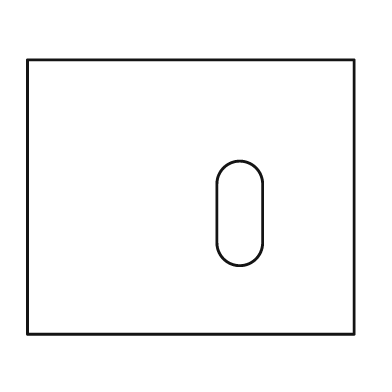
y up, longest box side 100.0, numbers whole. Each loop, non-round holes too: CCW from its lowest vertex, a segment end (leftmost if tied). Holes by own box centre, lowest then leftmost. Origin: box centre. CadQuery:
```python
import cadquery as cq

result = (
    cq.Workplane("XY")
    .moveTo(-50.0, -42.0)
    .lineTo(50.0, -42.0)
    .lineTo(50.0, 42.0)
    .lineTo(-50.0, 42.0)
    .close()
    .moveTo(8.0, -14.0)
    .threePointArc((15.0, -21.0), (22.0, -14.0))
    .lineTo(22.0, 4.0)
    .threePointArc((15.0, 11.0), (8.0, 4.0))
    .close()
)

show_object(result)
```